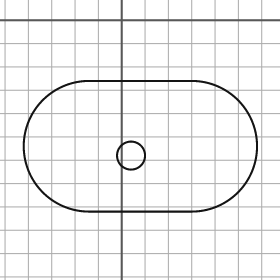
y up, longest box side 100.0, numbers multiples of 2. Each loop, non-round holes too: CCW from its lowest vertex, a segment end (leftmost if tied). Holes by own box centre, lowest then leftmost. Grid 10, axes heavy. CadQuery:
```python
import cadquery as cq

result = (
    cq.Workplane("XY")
    .moveTo(-14.0, -82.0)
    .lineTo(30.0, -82.0)
    .threePointArc((58.0, -54.0), (30.0, -26.0))
    .lineTo(-14.0, -26.0)
    .threePointArc((-42.0, -54.0), (-14.0, -82.0))
    .close()
    .moveTo(4.0, -58.0)
    .circle(6.0)
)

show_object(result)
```